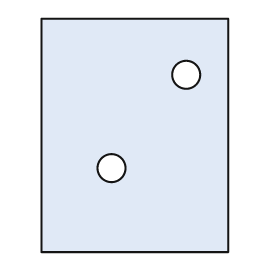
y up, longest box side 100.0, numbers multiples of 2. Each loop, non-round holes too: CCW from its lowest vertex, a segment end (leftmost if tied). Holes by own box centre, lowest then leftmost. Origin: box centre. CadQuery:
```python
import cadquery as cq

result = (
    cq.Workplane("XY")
    .moveTo(-40.0, -50.0)
    .lineTo(40.0, -50.0)
    .lineTo(40.0, 50.0)
    .lineTo(-40.0, 50.0)
    .close()
    .moveTo(-10.0, -14.0)
    .circle(6.0)
    .moveTo(22.0, 26.0)
    .circle(6.0)
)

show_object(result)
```